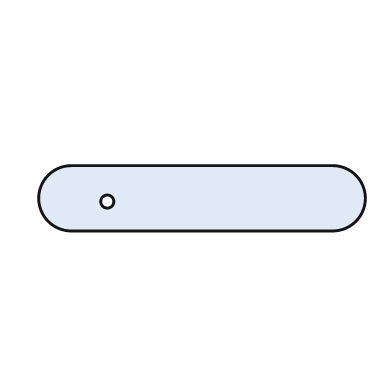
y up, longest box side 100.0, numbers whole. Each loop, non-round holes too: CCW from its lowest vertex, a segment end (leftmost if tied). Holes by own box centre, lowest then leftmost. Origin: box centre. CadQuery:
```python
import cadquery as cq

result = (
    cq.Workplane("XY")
    .moveTo(-40.0, -10.0)
    .lineTo(40.0, -10.0)
    .threePointArc((50.0, 0.0), (40.0, 10.0))
    .lineTo(-40.0, 10.0)
    .threePointArc((-50.0, 0.0), (-40.0, -10.0))
    .close()
    .moveTo(-29.0, -1.0)
    .circle(2.0)
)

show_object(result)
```